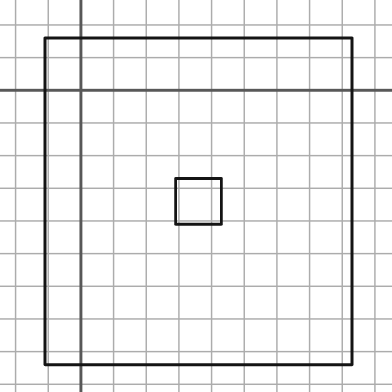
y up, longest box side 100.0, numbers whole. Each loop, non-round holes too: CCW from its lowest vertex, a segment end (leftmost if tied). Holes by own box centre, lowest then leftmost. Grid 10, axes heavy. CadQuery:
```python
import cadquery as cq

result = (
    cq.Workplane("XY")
    .moveTo(-11.0, -84.0)
    .lineTo(83.0, -84.0)
    .lineTo(83.0, 16.0)
    .lineTo(-11.0, 16.0)
    .close()
    .moveTo(29.0, -41.0)
    .lineTo(43.0, -41.0)
    .lineTo(43.0, -27.0)
    .lineTo(29.0, -27.0)
    .close()
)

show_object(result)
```